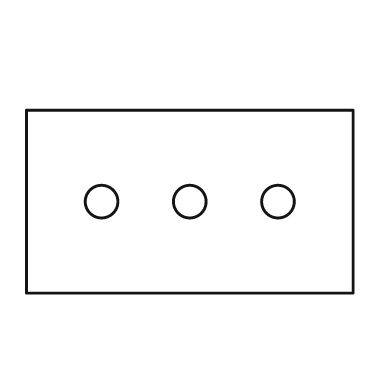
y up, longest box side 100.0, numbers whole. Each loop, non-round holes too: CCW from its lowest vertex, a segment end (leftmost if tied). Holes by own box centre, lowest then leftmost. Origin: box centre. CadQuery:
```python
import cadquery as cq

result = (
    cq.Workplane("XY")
    .moveTo(-50.0, -28.0)
    .lineTo(50.0, -28.0)
    .lineTo(50.0, 28.0)
    .lineTo(-50.0, 28.0)
    .close()
    .moveTo(-27.0, 0.0)
    .circle(5.0)
    .moveTo(0.0, 0.0)
    .circle(5.0)
    .moveTo(27.0, 0.0)
    .circle(5.0)
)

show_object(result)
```